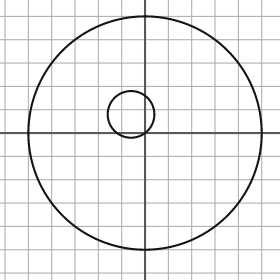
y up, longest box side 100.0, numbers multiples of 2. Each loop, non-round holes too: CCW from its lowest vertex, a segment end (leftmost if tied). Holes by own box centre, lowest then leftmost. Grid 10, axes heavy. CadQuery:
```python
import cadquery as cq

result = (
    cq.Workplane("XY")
    .moveTo(0.0, 0.0)
    .circle(50.0)
    .moveTo(-6.0, 8.0)
    .circle(10.0)
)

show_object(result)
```